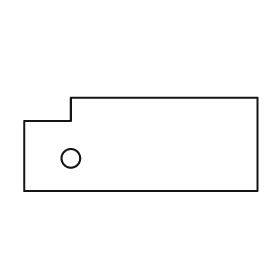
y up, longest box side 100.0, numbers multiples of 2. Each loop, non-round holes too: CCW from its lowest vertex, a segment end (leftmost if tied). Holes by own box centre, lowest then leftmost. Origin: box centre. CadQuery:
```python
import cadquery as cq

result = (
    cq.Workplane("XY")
    .moveTo(-50.0, -20.0)
    .lineTo(50.0, -20.0)
    .lineTo(50.0, 20.0)
    .lineTo(-30.0, 20.0)
    .lineTo(-30.0, 10.0)
    .lineTo(-50.0, 10.0)
    .close()
    .moveTo(-30.0, -6.0)
    .circle(4.0)
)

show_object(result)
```